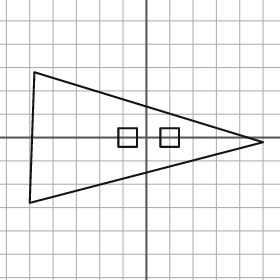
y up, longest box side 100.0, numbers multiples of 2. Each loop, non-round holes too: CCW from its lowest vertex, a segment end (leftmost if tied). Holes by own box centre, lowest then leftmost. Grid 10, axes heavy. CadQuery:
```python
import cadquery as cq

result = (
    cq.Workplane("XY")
    .moveTo(-50.0, -28.0)
    .lineTo(50.0, -2.0)
    .lineTo(-48.0, 28.0)
    .close()
    .moveTo(-12.0, -4.0)
    .lineTo(-4.0, -4.0)
    .lineTo(-4.0, 4.0)
    .lineTo(-12.0, 4.0)
    .close()
    .moveTo(6.0, -4.0)
    .lineTo(14.0, -4.0)
    .lineTo(14.0, 4.0)
    .lineTo(6.0, 4.0)
    .close()
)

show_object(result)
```